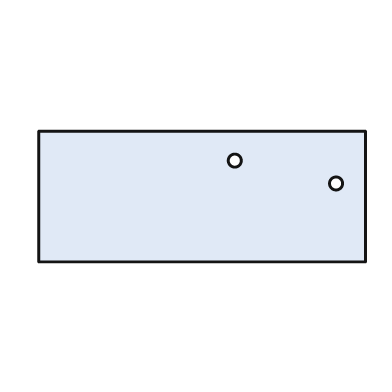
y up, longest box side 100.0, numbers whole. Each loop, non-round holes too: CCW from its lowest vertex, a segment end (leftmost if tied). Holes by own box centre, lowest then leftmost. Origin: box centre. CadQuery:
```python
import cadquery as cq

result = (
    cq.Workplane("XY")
    .moveTo(-50.0, -20.0)
    .lineTo(50.0, -20.0)
    .lineTo(50.0, 20.0)
    .lineTo(-50.0, 20.0)
    .close()
    .moveTo(41.0, 4.0)
    .circle(2.0)
    .moveTo(10.0, 11.0)
    .circle(2.0)
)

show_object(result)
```